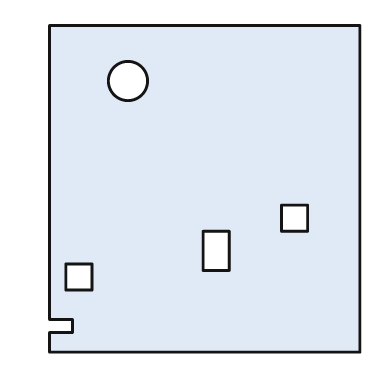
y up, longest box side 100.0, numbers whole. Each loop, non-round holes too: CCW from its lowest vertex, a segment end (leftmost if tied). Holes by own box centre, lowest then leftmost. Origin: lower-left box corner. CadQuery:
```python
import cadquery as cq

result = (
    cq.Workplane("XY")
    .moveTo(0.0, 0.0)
    .lineTo(95.0, 0.0)
    .lineTo(95.0, 100.0)
    .lineTo(0.0, 100.0)
    .lineTo(0.0, 10.0)
    .lineTo(7.0, 10.0)
    .lineTo(7.0, 6.0)
    .lineTo(0.0, 6.0)
    .close()
    .moveTo(5.0, 19.0)
    .lineTo(13.0, 19.0)
    .lineTo(13.0, 27.0)
    .lineTo(5.0, 27.0)
    .close()
    .moveTo(47.0, 25.0)
    .lineTo(55.0, 25.0)
    .lineTo(55.0, 37.0)
    .lineTo(47.0, 37.0)
    .close()
    .moveTo(71.0, 37.0)
    .lineTo(79.0, 37.0)
    .lineTo(79.0, 45.0)
    .lineTo(71.0, 45.0)
    .close()
    .moveTo(24.0, 83.0)
    .circle(6.0)
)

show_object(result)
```